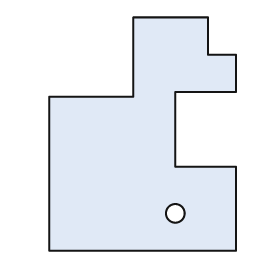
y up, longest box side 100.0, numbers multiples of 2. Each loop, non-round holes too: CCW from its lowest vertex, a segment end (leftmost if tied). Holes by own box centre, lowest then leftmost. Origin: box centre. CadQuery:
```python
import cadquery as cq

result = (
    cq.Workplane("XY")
    .moveTo(-40.0, -50.0)
    .lineTo(40.0, -50.0)
    .lineTo(40.0, -14.0)
    .lineTo(14.0, -14.0)
    .lineTo(14.0, 18.0)
    .lineTo(40.0, 18.0)
    .lineTo(40.0, 34.0)
    .lineTo(28.0, 34.0)
    .lineTo(28.0, 50.0)
    .lineTo(-4.0, 50.0)
    .lineTo(-4.0, 16.0)
    .lineTo(-40.0, 16.0)
    .close()
    .moveTo(14.0, -34.0)
    .circle(4.0)
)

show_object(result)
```